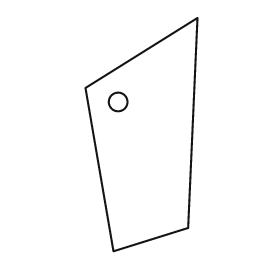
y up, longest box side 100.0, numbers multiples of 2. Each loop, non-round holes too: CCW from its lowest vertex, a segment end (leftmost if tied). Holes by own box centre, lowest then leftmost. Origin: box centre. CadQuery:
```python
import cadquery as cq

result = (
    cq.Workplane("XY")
    .moveTo(-12.0, -50.0)
    .lineTo(20.0, -40.0)
    .lineTo(24.0, 50.0)
    .lineTo(-24.0, 20.0)
    .close()
    .moveTo(-10.0, 14.0)
    .circle(4.0)
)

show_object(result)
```